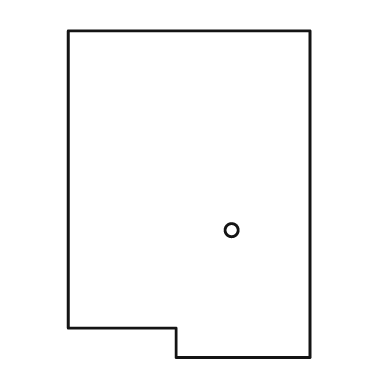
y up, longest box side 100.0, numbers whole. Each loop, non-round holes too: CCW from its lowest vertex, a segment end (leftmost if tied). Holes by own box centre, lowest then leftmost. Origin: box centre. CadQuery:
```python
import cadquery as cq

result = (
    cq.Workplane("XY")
    .moveTo(-4.0, -50.0)
    .lineTo(37.0, -50.0)
    .lineTo(37.0, 50.0)
    .lineTo(-37.0, 50.0)
    .lineTo(-37.0, -41.0)
    .lineTo(-4.0, -41.0)
    .close()
    .moveTo(13.0, -11.0)
    .circle(2.0)
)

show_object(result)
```